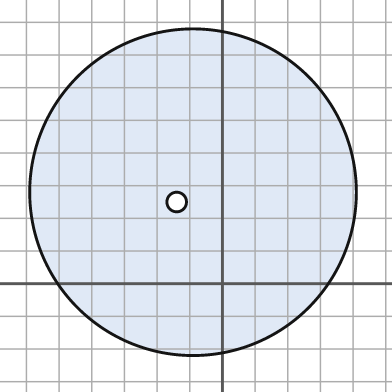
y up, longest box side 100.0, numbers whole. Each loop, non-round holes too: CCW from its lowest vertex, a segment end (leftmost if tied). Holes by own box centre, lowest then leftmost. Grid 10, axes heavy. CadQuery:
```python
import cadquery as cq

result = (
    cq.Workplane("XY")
    .moveTo(-9.0, 28.0)
    .circle(50.0)
    .moveTo(-14.0, 25.0)
    .circle(3.0)
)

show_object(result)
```